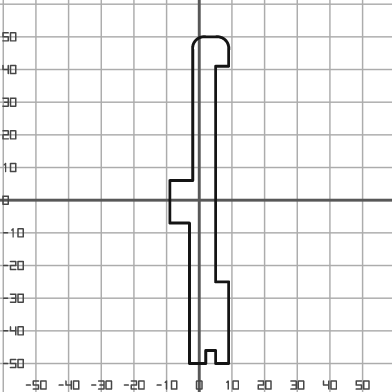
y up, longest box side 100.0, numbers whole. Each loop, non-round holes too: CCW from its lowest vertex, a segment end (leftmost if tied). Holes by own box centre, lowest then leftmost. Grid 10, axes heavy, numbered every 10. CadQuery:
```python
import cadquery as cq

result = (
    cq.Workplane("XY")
    .moveTo(-3.0, -50.0)
    .lineTo(2.0, -50.0)
    .lineTo(2.0, -46.0)
    .lineTo(5.0, -46.0)
    .lineTo(5.0, -50.0)
    .lineTo(9.0, -50.0)
    .lineTo(9.0, -25.0)
    .lineTo(5.0, -25.0)
    .lineTo(5.0, 41.0)
    .lineTo(9.0, 41.0)
    .lineTo(9.0, 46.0)
    .threePointArc((8.0, 49.0), (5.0, 50.0))
    .lineTo(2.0, 50.0)
    .threePointArc((-1.0, 49.0), (-2.0, 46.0))
    .lineTo(-2.0, 6.0)
    .lineTo(-9.0, 6.0)
    .lineTo(-9.0, -7.0)
    .lineTo(-3.0, -7.0)
    .close()
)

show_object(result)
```